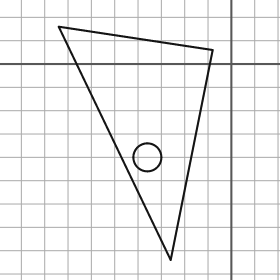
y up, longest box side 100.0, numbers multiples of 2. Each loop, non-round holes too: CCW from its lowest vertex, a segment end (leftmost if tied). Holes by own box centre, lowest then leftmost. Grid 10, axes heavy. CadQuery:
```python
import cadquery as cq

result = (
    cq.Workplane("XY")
    .moveTo(-26.0, -84.0)
    .lineTo(-8.0, 6.0)
    .lineTo(-74.0, 16.0)
    .close()
    .moveTo(-36.0, -40.0)
    .circle(6.0)
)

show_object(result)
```